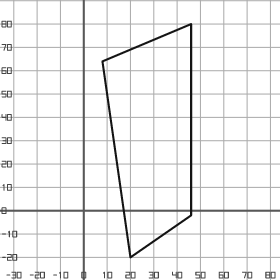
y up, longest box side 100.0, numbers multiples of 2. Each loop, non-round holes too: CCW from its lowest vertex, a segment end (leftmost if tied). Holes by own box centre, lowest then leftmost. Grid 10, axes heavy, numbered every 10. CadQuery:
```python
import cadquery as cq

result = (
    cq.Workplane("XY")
    .moveTo(20.0, -20.0)
    .lineTo(46.0, -2.0)
    .lineTo(46.0, 80.0)
    .lineTo(8.0, 64.0)
    .close()
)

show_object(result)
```